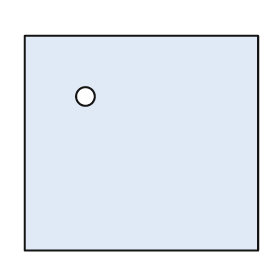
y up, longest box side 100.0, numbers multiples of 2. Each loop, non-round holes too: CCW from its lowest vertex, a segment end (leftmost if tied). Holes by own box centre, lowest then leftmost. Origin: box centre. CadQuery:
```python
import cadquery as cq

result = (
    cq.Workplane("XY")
    .moveTo(-50.0, -46.0)
    .lineTo(50.0, -46.0)
    .lineTo(50.0, 46.0)
    .lineTo(-50.0, 46.0)
    .close()
    .moveTo(-24.0, 20.0)
    .circle(4.0)
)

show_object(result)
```